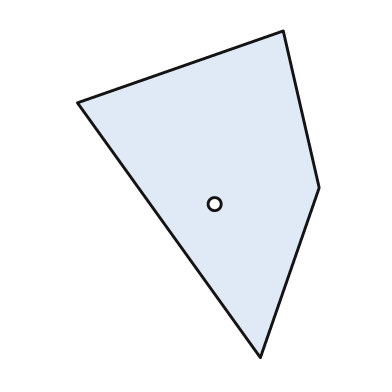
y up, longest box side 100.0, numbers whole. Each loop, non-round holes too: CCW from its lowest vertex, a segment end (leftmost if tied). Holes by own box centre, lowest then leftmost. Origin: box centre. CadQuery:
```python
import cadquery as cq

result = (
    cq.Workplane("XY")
    .moveTo(19.0, -50.0)
    .lineTo(37.0, 2.0)
    .lineTo(26.0, 50.0)
    .lineTo(-37.0, 28.0)
    .close()
    .moveTo(5.0, -3.0)
    .circle(2.0)
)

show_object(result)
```